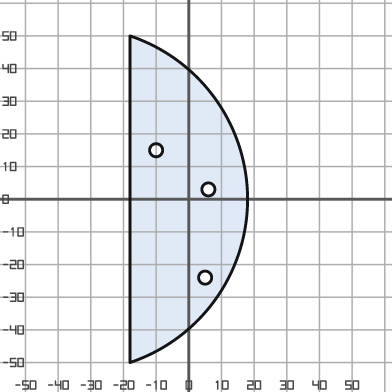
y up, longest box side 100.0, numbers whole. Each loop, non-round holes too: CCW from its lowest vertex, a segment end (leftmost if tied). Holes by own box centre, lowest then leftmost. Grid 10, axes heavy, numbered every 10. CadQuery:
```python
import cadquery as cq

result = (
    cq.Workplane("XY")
    .moveTo(-18.0, -50.0)
    .threePointArc((18.0, 0.0), (-18.0, 50.0))
    .close()
    .moveTo(5.0, -24.0)
    .circle(2.0)
    .moveTo(6.0, 3.0)
    .circle(2.0)
    .moveTo(-10.0, 15.0)
    .circle(2.0)
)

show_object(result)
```